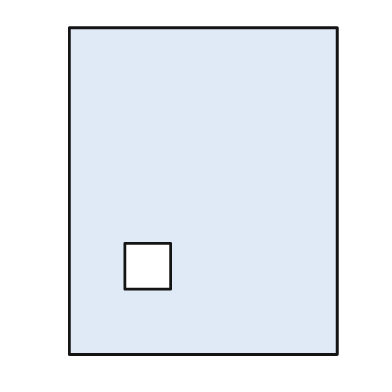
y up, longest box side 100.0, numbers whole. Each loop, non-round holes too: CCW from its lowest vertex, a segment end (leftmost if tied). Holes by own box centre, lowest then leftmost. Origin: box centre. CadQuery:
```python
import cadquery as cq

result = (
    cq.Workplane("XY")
    .moveTo(-41.0, -50.0)
    .lineTo(41.0, -50.0)
    .lineTo(41.0, 50.0)
    .lineTo(-41.0, 50.0)
    .close()
    .moveTo(-24.0, -30.0)
    .lineTo(-10.0, -30.0)
    .lineTo(-10.0, -16.0)
    .lineTo(-24.0, -16.0)
    .close()
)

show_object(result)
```